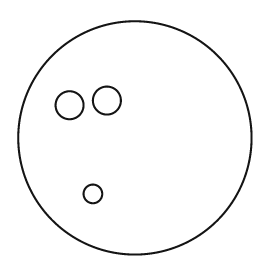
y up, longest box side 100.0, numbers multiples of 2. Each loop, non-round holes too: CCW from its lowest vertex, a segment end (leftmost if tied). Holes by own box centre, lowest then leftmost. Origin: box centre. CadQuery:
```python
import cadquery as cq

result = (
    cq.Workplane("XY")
    .moveTo(0.0, 0.0)
    .circle(50.0)
    .moveTo(-18.0, -24.0)
    .circle(4.0)
    .moveTo(-28.0, 14.0)
    .circle(6.0)
    .moveTo(-12.0, 16.0)
    .circle(6.0)
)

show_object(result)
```